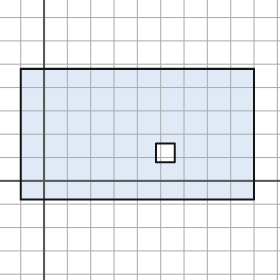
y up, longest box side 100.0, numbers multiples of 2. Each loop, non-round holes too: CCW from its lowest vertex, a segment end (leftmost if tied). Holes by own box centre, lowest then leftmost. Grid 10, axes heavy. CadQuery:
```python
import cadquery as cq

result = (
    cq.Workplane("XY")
    .moveTo(-10.0, -8.0)
    .lineTo(90.0, -8.0)
    .lineTo(90.0, 48.0)
    .lineTo(-10.0, 48.0)
    .close()
    .moveTo(48.0, 8.0)
    .lineTo(56.0, 8.0)
    .lineTo(56.0, 16.0)
    .lineTo(48.0, 16.0)
    .close()
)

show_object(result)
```